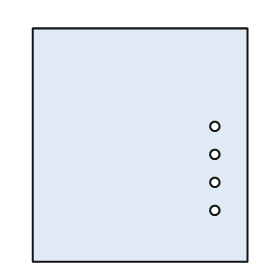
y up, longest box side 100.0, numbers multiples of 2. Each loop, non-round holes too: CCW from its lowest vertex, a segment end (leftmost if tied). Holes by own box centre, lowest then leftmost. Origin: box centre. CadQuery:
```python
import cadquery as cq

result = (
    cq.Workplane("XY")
    .moveTo(-46.0, -50.0)
    .lineTo(46.0, -50.0)
    .lineTo(46.0, 50.0)
    .lineTo(-46.0, 50.0)
    .close()
    .moveTo(32.0, -28.0)
    .circle(2.0)
    .moveTo(32.0, -16.0)
    .circle(2.0)
    .moveTo(32.0, -4.0)
    .circle(2.0)
    .moveTo(32.0, 8.0)
    .circle(2.0)
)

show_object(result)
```